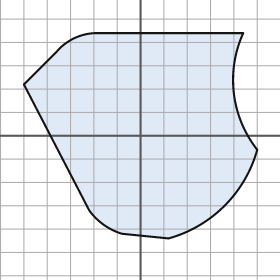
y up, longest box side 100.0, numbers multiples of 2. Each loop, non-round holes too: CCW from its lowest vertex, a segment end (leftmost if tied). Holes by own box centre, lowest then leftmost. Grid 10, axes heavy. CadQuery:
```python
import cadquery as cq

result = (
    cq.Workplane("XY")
    .moveTo(12.0, -44.0)
    .threePointArc((36.0, -30.0), (50.0, -6.0))
    .threePointArc((40.0, 18.0), (44.0, 44.0))
    .lineTo(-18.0, 44.0)
    .threePointArc((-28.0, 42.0), (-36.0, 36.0))
    .lineTo(-50.0, 22.0)
    .lineTo(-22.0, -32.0)
    .threePointArc((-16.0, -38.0), (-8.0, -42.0))
    .close()
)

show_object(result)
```